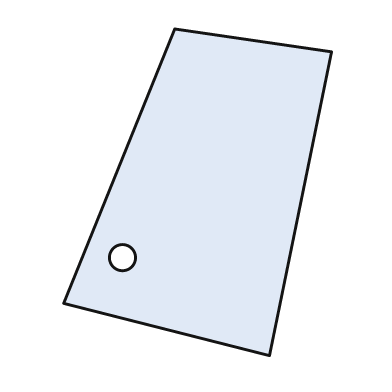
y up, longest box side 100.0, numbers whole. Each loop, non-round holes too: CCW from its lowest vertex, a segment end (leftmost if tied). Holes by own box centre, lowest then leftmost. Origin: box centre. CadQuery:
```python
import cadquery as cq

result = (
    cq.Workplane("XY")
    .moveTo(22.0, -50.0)
    .lineTo(41.0, 43.0)
    .lineTo(-7.0, 50.0)
    .lineTo(-41.0, -34.0)
    .close()
    .moveTo(-23.0, -20.0)
    .circle(4.0)
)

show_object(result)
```